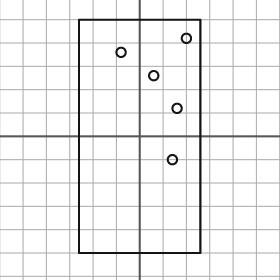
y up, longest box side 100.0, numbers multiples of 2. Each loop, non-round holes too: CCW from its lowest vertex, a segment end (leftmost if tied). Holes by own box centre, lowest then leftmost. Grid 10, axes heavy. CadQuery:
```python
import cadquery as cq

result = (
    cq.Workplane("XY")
    .moveTo(-26.0, -50.0)
    .lineTo(26.0, -50.0)
    .lineTo(26.0, 50.0)
    .lineTo(-26.0, 50.0)
    .close()
    .moveTo(14.0, -10.0)
    .circle(2.0)
    .moveTo(16.0, 12.0)
    .circle(2.0)
    .moveTo(6.0, 26.0)
    .circle(2.0)
    .moveTo(-8.0, 36.0)
    .circle(2.0)
    .moveTo(20.0, 42.0)
    .circle(2.0)
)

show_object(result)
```